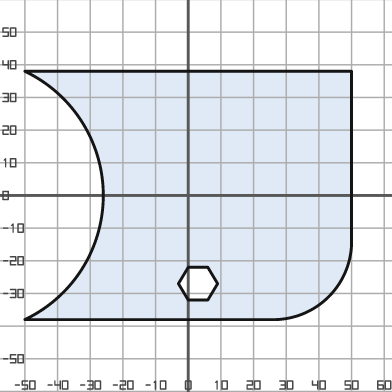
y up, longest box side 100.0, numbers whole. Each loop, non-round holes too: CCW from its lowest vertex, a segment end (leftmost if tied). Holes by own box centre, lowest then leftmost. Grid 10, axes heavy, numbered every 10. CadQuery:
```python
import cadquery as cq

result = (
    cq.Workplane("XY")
    .moveTo(-50.0, -38.0)
    .lineTo(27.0, -38.0)
    .threePointArc((43.0, -31.0), (50.0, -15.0))
    .lineTo(50.0, 38.0)
    .lineTo(-50.0, 38.0)
    .threePointArc((-26.0, 0.0), (-50.0, -38.0))
    .close()
    .moveTo(0.0, -32.0)
    .lineTo(6.0, -32.0)
    .lineTo(9.0, -27.0)
    .lineTo(6.0, -22.0)
    .lineTo(0.0, -22.0)
    .lineTo(-3.0, -27.0)
    .close()
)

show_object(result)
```